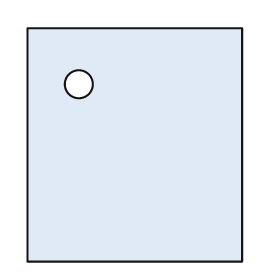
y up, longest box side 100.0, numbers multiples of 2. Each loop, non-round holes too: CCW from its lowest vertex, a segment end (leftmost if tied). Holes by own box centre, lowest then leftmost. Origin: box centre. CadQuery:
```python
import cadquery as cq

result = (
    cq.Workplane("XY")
    .moveTo(-46.0, -50.0)
    .lineTo(46.0, -50.0)
    .lineTo(46.0, 50.0)
    .lineTo(-46.0, 50.0)
    .close()
    .moveTo(-24.0, 26.0)
    .circle(6.0)
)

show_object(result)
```